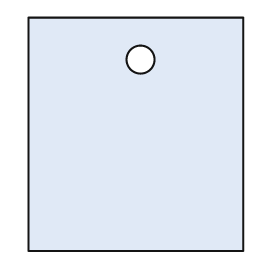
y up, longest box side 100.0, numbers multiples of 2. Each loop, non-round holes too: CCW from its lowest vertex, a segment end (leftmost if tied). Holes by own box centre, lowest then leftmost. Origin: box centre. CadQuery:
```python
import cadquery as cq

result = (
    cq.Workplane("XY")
    .moveTo(-46.0, -50.0)
    .lineTo(46.0, -50.0)
    .lineTo(46.0, 50.0)
    .lineTo(-46.0, 50.0)
    .close()
    .moveTo(2.0, 32.0)
    .circle(6.0)
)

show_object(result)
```